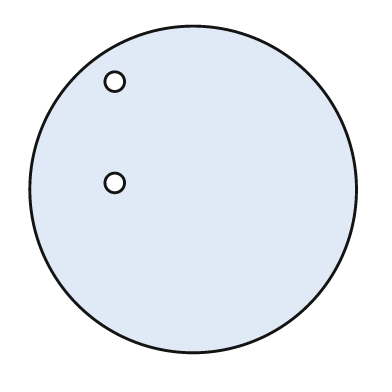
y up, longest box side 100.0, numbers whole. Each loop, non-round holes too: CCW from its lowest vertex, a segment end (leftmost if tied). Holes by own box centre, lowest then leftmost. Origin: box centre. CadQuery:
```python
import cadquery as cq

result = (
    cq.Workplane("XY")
    .moveTo(0.0, 0.0)
    .circle(50.0)
    .moveTo(-24.0, 2.0)
    .circle(3.0)
    .moveTo(-24.0, 33.0)
    .circle(3.0)
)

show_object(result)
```